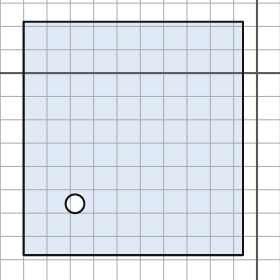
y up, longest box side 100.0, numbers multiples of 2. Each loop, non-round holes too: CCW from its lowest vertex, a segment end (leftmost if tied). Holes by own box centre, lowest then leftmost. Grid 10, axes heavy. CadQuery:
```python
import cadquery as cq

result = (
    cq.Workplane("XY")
    .moveTo(-100.0, -78.0)
    .lineTo(-6.0, -78.0)
    .lineTo(-6.0, 22.0)
    .lineTo(-100.0, 22.0)
    .close()
    .moveTo(-78.0, -56.0)
    .circle(4.0)
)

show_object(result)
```